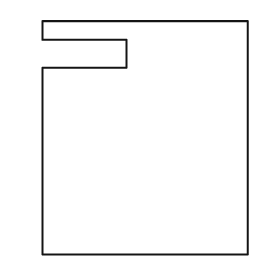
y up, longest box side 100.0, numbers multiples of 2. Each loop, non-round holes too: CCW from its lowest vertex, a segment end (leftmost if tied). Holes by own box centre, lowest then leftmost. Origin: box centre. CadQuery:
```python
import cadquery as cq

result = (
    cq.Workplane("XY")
    .moveTo(-44.0, -50.0)
    .lineTo(44.0, -50.0)
    .lineTo(44.0, 50.0)
    .lineTo(-44.0, 50.0)
    .lineTo(-44.0, 42.0)
    .lineTo(-8.0, 42.0)
    .lineTo(-8.0, 30.0)
    .lineTo(-44.0, 30.0)
    .close()
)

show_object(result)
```